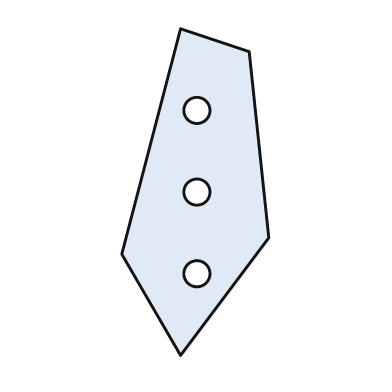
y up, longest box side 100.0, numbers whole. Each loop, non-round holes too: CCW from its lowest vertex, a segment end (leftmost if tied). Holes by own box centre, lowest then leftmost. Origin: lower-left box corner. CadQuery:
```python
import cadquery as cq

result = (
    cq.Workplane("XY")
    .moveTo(18.0, 0.0)
    .lineTo(45.0, 36.0)
    .lineTo(39.0, 93.0)
    .lineTo(18.0, 100.0)
    .lineTo(0.0, 31.0)
    .close()
    .moveTo(23.0, 25.0)
    .circle(4.0)
    .moveTo(23.0, 50.0)
    .circle(4.0)
    .moveTo(23.0, 75.0)
    .circle(4.0)
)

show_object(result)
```